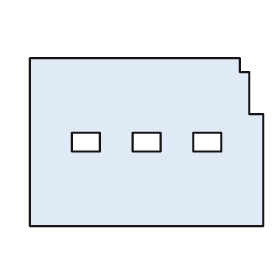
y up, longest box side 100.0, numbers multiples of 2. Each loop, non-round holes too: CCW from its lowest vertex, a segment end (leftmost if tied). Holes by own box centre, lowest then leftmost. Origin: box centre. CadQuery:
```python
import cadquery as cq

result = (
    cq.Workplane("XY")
    .moveTo(-50.0, -36.0)
    .lineTo(50.0, -36.0)
    .lineTo(50.0, 12.0)
    .lineTo(44.0, 12.0)
    .lineTo(44.0, 30.0)
    .lineTo(40.0, 30.0)
    .lineTo(40.0, 36.0)
    .lineTo(-50.0, 36.0)
    .close()
    .moveTo(-32.0, -4.0)
    .lineTo(-20.0, -4.0)
    .lineTo(-20.0, 4.0)
    .lineTo(-32.0, 4.0)
    .close()
    .moveTo(-6.0, -4.0)
    .lineTo(6.0, -4.0)
    .lineTo(6.0, 4.0)
    .lineTo(-6.0, 4.0)
    .close()
    .moveTo(20.0, -4.0)
    .lineTo(32.0, -4.0)
    .lineTo(32.0, 4.0)
    .lineTo(20.0, 4.0)
    .close()
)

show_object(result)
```